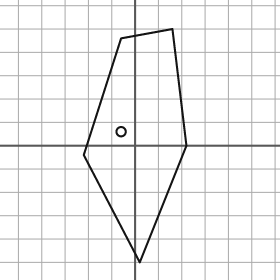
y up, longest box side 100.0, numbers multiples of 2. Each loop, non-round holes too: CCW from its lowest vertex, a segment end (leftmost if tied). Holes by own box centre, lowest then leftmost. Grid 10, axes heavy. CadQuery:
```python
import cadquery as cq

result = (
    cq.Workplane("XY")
    .moveTo(2.0, -50.0)
    .lineTo(22.0, 0.0)
    .lineTo(16.0, 50.0)
    .lineTo(-6.0, 46.0)
    .lineTo(-22.0, -4.0)
    .close()
    .moveTo(-6.0, 6.0)
    .circle(2.0)
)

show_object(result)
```